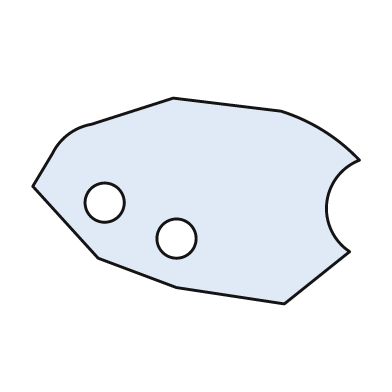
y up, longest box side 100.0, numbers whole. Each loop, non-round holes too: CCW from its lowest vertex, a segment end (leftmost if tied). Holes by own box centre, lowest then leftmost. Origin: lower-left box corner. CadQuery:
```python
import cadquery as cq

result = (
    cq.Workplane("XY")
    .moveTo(77.0, 0.0)
    .lineTo(97.0, 16.0)
    .threePointArc((90.0, 31.0), (100.0, 44.0))
    .threePointArc((89.0, 53.0), (76.0, 59.0))
    .lineTo(43.0, 63.0)
    .lineTo(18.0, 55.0)
    .threePointArc((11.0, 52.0), (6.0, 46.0))
    .lineTo(0.0, 36.0)
    .lineTo(20.0, 14.0)
    .lineTo(44.0, 5.0)
    .close()
    .moveTo(44.0, 20.0)
    .circle(6.0)
    .moveTo(22.0, 31.0)
    .circle(6.0)
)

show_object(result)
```